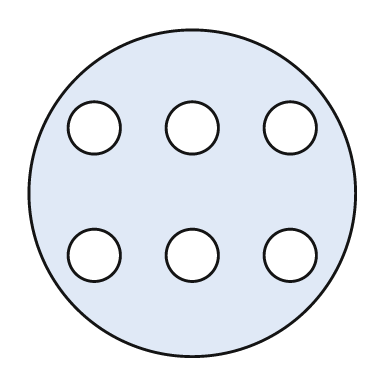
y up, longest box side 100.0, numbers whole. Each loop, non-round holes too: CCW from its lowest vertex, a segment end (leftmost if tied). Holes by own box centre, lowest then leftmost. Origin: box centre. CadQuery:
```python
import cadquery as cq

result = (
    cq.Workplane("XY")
    .moveTo(0.0, 0.0)
    .circle(50.0)
    .moveTo(-30.0, -19.0)
    .circle(8.0)
    .moveTo(0.0, -19.0)
    .circle(8.0)
    .moveTo(30.0, -19.0)
    .circle(8.0)
    .moveTo(-30.0, 20.0)
    .circle(8.0)
    .moveTo(0.0, 20.0)
    .circle(8.0)
    .moveTo(30.0, 20.0)
    .circle(8.0)
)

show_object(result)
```